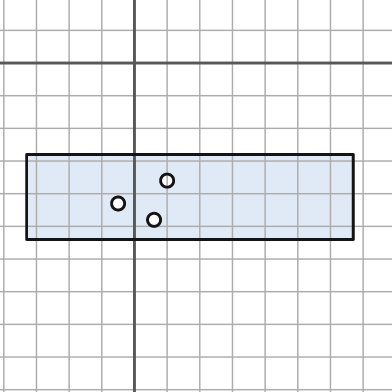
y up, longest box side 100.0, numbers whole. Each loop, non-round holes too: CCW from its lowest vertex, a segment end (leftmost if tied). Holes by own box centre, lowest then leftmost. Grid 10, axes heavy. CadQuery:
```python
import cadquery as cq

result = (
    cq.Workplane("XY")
    .moveTo(-33.0, -54.0)
    .lineTo(67.0, -54.0)
    .lineTo(67.0, -28.0)
    .lineTo(-33.0, -28.0)
    .close()
    .moveTo(6.0, -48.0)
    .circle(2.0)
    .moveTo(-5.0, -43.0)
    .circle(2.0)
    .moveTo(10.0, -36.0)
    .circle(2.0)
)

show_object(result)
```